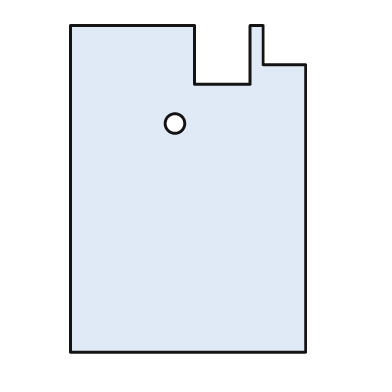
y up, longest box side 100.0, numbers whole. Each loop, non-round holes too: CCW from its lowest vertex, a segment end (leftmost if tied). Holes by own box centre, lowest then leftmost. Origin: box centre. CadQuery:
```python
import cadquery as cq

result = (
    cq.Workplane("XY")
    .moveTo(-36.0, -50.0)
    .lineTo(36.0, -50.0)
    .lineTo(36.0, 38.0)
    .lineTo(23.0, 38.0)
    .lineTo(23.0, 50.0)
    .lineTo(19.0, 50.0)
    .lineTo(19.0, 32.0)
    .lineTo(2.0, 32.0)
    .lineTo(2.0, 50.0)
    .lineTo(-36.0, 50.0)
    .close()
    .moveTo(-4.0, 20.0)
    .circle(3.0)
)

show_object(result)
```